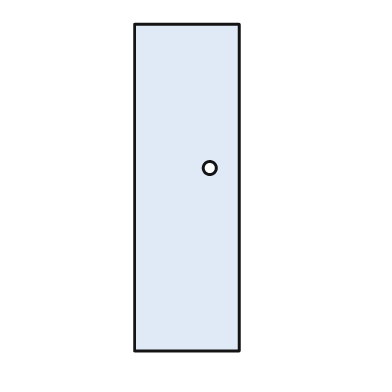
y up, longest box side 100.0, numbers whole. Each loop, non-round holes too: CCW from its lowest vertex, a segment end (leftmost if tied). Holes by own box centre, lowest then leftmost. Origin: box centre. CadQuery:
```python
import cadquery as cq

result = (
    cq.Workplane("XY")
    .moveTo(-16.0, -50.0)
    .lineTo(16.0, -50.0)
    .lineTo(16.0, 50.0)
    .lineTo(-16.0, 50.0)
    .close()
    .moveTo(7.0, 6.0)
    .circle(2.0)
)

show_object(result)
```